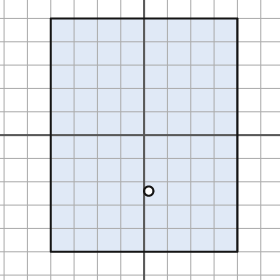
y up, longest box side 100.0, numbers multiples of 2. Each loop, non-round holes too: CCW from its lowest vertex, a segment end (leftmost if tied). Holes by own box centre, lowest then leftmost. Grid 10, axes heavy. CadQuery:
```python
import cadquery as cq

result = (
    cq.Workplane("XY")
    .moveTo(-40.0, -50.0)
    .lineTo(40.0, -50.0)
    .lineTo(40.0, 50.0)
    .lineTo(-40.0, 50.0)
    .close()
    .moveTo(2.0, -24.0)
    .circle(2.0)
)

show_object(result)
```